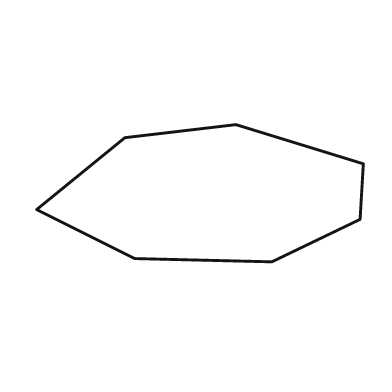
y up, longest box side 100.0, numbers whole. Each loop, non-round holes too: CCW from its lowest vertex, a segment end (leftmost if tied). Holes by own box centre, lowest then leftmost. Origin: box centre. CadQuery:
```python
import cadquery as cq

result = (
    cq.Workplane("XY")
    .moveTo(22.0, -21.0)
    .lineTo(49.0, -8.0)
    .lineTo(50.0, 9.0)
    .lineTo(11.0, 21.0)
    .lineTo(-23.0, 17.0)
    .lineTo(-50.0, -5.0)
    .lineTo(-20.0, -20.0)
    .close()
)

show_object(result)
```